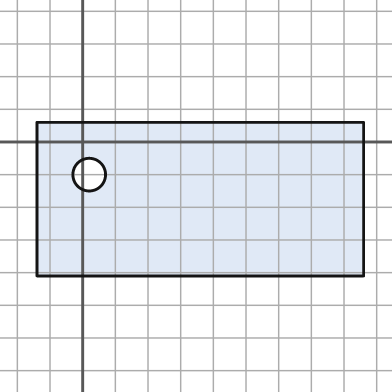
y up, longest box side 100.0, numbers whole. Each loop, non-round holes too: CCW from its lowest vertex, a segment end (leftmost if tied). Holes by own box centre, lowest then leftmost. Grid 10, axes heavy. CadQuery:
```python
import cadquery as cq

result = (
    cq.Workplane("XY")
    .moveTo(-14.0, -41.0)
    .lineTo(86.0, -41.0)
    .lineTo(86.0, 6.0)
    .lineTo(-14.0, 6.0)
    .close()
    .moveTo(2.0, -10.0)
    .circle(5.0)
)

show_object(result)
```